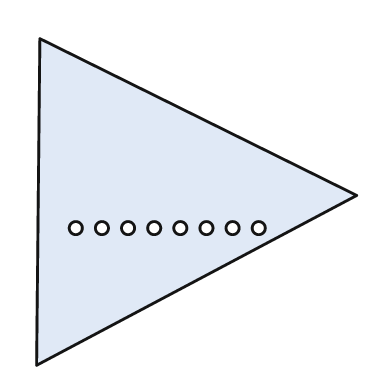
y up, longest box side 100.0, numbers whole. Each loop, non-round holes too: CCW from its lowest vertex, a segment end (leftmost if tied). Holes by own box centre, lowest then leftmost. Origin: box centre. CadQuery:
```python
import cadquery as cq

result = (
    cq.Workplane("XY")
    .moveTo(-49.0, -50.0)
    .lineTo(49.0, 2.0)
    .lineTo(-48.0, 50.0)
    .close()
    .moveTo(-37.0, -8.0)
    .circle(2.0)
    .moveTo(-29.0, -8.0)
    .circle(2.0)
    .moveTo(-21.0, -8.0)
    .circle(2.0)
    .moveTo(-13.0, -8.0)
    .circle(2.0)
    .moveTo(-5.0, -8.0)
    .circle(2.0)
    .moveTo(3.0, -8.0)
    .circle(2.0)
    .moveTo(11.0, -8.0)
    .circle(2.0)
    .moveTo(19.0, -8.0)
    .circle(2.0)
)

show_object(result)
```